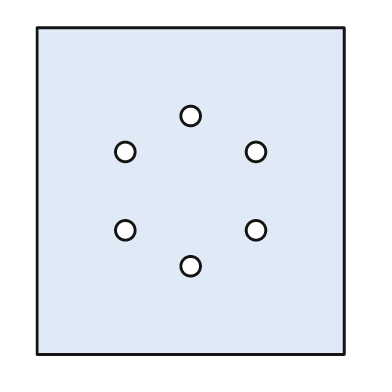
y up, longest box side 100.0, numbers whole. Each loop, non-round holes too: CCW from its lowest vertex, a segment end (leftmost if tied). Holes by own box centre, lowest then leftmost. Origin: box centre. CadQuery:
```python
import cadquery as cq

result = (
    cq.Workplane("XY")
    .moveTo(-47.0, -50.0)
    .lineTo(47.0, -50.0)
    .lineTo(47.0, 50.0)
    .lineTo(-47.0, 50.0)
    .close()
    .moveTo(0.0, -23.0)
    .circle(3.0)
    .moveTo(-20.0, -12.0)
    .circle(3.0)
    .moveTo(20.0, -12.0)
    .circle(3.0)
    .moveTo(-20.0, 12.0)
    .circle(3.0)
    .moveTo(20.0, 12.0)
    .circle(3.0)
    .moveTo(0.0, 23.0)
    .circle(3.0)
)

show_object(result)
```